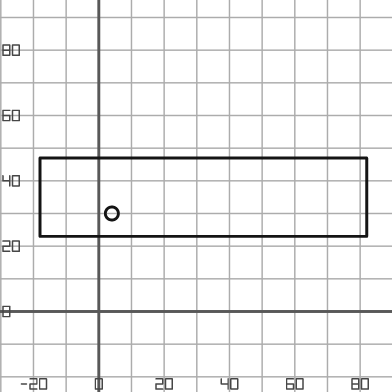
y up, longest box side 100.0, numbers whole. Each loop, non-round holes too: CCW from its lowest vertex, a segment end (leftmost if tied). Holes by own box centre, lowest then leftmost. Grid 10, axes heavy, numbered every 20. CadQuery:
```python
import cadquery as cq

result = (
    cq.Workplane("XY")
    .moveTo(-18.0, 23.0)
    .lineTo(82.0, 23.0)
    .lineTo(82.0, 47.0)
    .lineTo(-18.0, 47.0)
    .close()
    .moveTo(4.0, 30.0)
    .circle(2.0)
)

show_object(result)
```